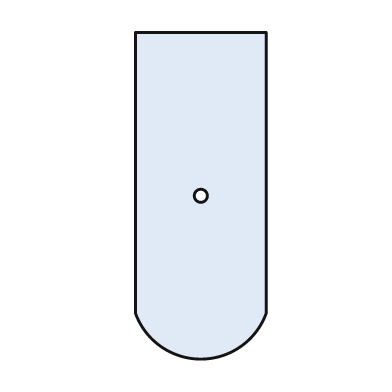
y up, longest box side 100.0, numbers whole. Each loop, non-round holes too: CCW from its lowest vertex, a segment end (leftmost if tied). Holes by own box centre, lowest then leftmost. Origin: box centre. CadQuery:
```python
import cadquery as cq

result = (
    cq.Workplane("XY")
    .moveTo(-20.0, -36.0)
    .threePointArc((0.0, -50.0), (20.0, -36.0))
    .lineTo(20.0, 50.0)
    .lineTo(-20.0, 50.0)
    .close()
    .moveTo(0.0, 0.0)
    .circle(2.0)
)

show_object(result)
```